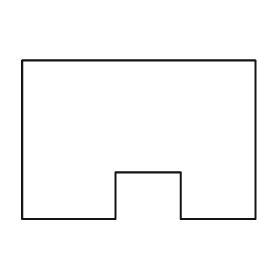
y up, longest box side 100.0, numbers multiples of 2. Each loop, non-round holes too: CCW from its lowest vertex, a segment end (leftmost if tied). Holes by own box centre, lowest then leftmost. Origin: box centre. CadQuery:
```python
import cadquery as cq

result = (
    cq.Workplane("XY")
    .moveTo(-50.0, -34.0)
    .lineTo(-10.0, -34.0)
    .lineTo(-10.0, -14.0)
    .lineTo(18.0, -14.0)
    .lineTo(18.0, -34.0)
    .lineTo(50.0, -34.0)
    .lineTo(50.0, 34.0)
    .lineTo(-50.0, 34.0)
    .close()
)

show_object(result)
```